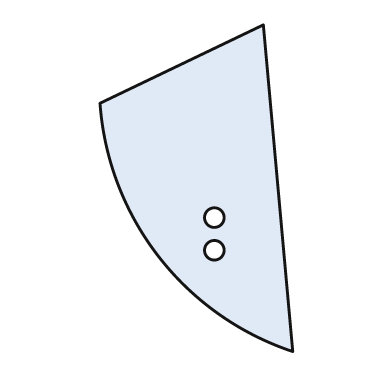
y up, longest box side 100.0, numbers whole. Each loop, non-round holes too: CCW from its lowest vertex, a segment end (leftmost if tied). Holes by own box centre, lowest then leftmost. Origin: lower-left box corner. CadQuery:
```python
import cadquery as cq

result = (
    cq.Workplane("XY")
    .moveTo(59.0, 0.0)
    .lineTo(50.0, 100.0)
    .lineTo(0.0, 76.0)
    .threePointArc((18.0, 29.0), (59.0, 0.0))
    .close()
    .moveTo(35.0, 31.0)
    .circle(3.0)
    .moveTo(35.0, 41.0)
    .circle(3.0)
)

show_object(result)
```